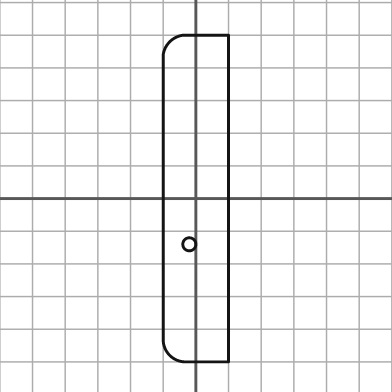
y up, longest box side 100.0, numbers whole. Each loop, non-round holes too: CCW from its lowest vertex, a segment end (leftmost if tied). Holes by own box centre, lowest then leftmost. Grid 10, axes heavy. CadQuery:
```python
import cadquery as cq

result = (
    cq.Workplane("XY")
    .moveTo(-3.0, -50.0)
    .lineTo(10.0, -50.0)
    .lineTo(10.0, 50.0)
    .lineTo(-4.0, 50.0)
    .threePointArc((-8.0, 48.0), (-10.0, 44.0))
    .lineTo(-10.0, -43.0)
    .threePointArc((-8.0, -48.0), (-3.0, -50.0))
    .close()
    .moveTo(-2.0, -14.0)
    .circle(2.0)
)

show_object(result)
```